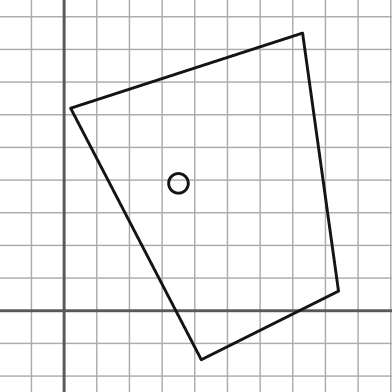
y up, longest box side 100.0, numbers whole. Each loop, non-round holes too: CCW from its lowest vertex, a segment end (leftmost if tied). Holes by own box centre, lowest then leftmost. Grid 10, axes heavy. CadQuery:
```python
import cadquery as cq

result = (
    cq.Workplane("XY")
    .moveTo(42.0, -15.0)
    .lineTo(84.0, 6.0)
    .lineTo(73.0, 85.0)
    .lineTo(2.0, 62.0)
    .close()
    .moveTo(35.0, 39.0)
    .circle(3.0)
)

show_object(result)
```